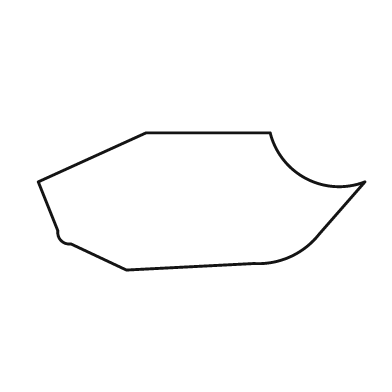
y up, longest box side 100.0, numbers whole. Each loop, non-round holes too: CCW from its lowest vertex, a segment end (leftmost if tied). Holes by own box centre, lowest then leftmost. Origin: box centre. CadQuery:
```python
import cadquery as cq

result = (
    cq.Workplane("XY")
    .moveTo(-23.0, -21.0)
    .lineTo(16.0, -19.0)
    .threePointArc((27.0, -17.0), (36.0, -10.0))
    .lineTo(50.0, 6.0)
    .threePointArc((32.0, 7.0), (21.0, 21.0))
    .lineTo(-17.0, 21.0)
    .lineTo(-50.0, 6.0)
    .lineTo(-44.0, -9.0)
    .threePointArc((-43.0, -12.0), (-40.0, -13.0))
    .close()
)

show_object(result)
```